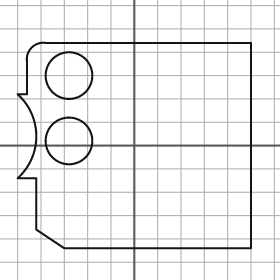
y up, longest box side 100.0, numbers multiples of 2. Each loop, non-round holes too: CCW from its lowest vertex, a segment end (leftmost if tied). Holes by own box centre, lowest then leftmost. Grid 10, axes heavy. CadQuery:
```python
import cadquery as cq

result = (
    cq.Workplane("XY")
    .moveTo(-30.0, -44.0)
    .lineTo(50.0, -44.0)
    .lineTo(50.0, 44.0)
    .lineTo(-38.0, 44.0)
    .threePointArc((-44.0, 42.0), (-46.0, 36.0))
    .lineTo(-46.0, 22.0)
    .lineTo(-50.0, 22.0)
    .threePointArc((-42.0, 4.0), (-50.0, -14.0))
    .lineTo(-42.0, -14.0)
    .lineTo(-42.0, -36.0)
    .close()
    .moveTo(-28.0, 2.0)
    .circle(10.0)
    .moveTo(-28.0, 30.0)
    .circle(10.0)
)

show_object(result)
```